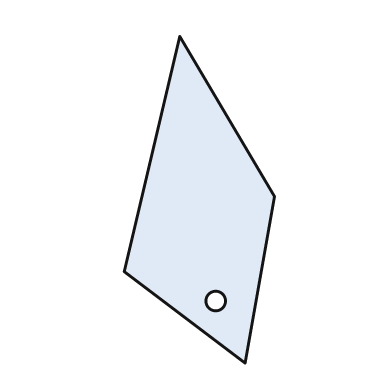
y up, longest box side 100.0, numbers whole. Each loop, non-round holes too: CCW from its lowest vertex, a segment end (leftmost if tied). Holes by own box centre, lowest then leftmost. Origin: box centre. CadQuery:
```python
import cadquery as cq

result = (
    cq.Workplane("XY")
    .moveTo(14.0, -50.0)
    .lineTo(23.0, 1.0)
    .lineTo(-6.0, 50.0)
    .lineTo(-23.0, -22.0)
    .close()
    .moveTo(5.0, -31.0)
    .circle(3.0)
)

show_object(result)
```